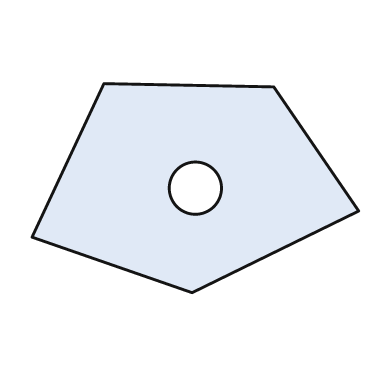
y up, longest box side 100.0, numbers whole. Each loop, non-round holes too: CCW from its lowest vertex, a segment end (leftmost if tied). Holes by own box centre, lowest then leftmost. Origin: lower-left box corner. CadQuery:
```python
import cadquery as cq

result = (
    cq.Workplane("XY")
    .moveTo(49.0, 0.0)
    .lineTo(100.0, 25.0)
    .lineTo(74.0, 63.0)
    .lineTo(22.0, 64.0)
    .lineTo(0.0, 17.0)
    .close()
    .moveTo(50.0, 32.0)
    .circle(8.0)
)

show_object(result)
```